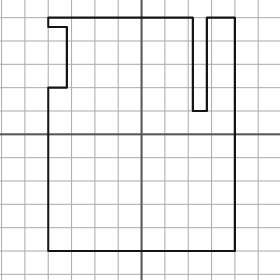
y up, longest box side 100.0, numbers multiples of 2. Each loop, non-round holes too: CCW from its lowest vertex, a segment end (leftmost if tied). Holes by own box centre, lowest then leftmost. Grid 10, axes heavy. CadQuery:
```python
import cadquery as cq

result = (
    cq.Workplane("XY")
    .moveTo(-40.0, -50.0)
    .lineTo(40.0, -50.0)
    .lineTo(40.0, 50.0)
    .lineTo(28.0, 50.0)
    .lineTo(28.0, 10.0)
    .lineTo(22.0, 10.0)
    .lineTo(22.0, 50.0)
    .lineTo(-40.0, 50.0)
    .lineTo(-40.0, 46.0)
    .lineTo(-32.0, 46.0)
    .lineTo(-32.0, 20.0)
    .lineTo(-40.0, 20.0)
    .close()
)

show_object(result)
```